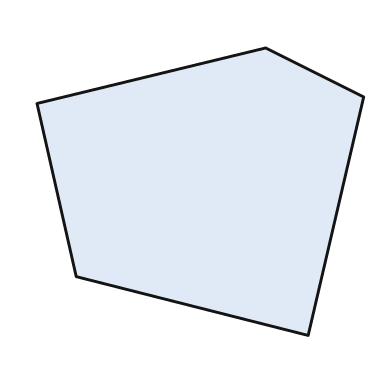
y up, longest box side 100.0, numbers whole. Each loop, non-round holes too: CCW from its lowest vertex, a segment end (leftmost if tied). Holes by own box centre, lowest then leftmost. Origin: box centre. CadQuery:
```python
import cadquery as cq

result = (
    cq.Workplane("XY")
    .moveTo(33.0, -44.0)
    .lineTo(50.0, 29.0)
    .lineTo(20.0, 44.0)
    .lineTo(-50.0, 27.0)
    .lineTo(-38.0, -26.0)
    .close()
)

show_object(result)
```